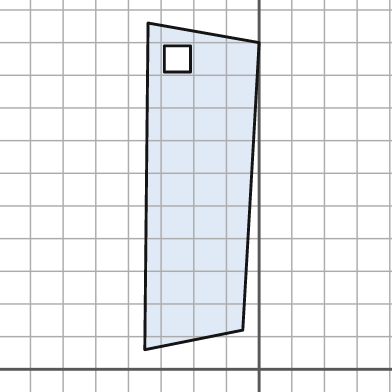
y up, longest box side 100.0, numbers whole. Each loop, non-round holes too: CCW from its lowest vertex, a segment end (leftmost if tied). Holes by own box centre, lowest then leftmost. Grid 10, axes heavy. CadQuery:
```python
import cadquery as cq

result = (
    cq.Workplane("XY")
    .moveTo(-35.0, 6.0)
    .lineTo(-5.0, 12.0)
    .lineTo(0.0, 100.0)
    .lineTo(-34.0, 106.0)
    .close()
    .moveTo(-29.0, 91.0)
    .lineTo(-21.0, 91.0)
    .lineTo(-21.0, 99.0)
    .lineTo(-29.0, 99.0)
    .close()
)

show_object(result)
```